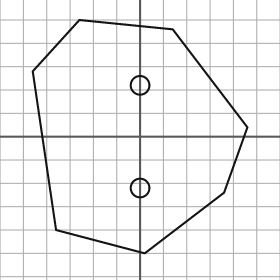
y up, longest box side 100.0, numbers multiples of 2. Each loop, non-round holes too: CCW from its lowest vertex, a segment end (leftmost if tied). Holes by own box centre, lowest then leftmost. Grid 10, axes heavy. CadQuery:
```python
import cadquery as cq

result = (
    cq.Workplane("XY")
    .moveTo(2.0, -50.0)
    .lineTo(36.0, -24.0)
    .lineTo(46.0, 4.0)
    .lineTo(14.0, 46.0)
    .lineTo(-26.0, 50.0)
    .lineTo(-46.0, 28.0)
    .lineTo(-36.0, -40.0)
    .close()
    .moveTo(0.0, -22.0)
    .circle(4.0)
    .moveTo(0.0, 22.0)
    .circle(4.0)
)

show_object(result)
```